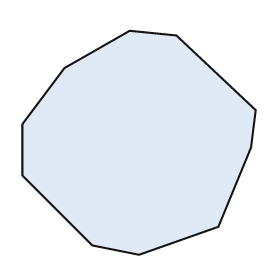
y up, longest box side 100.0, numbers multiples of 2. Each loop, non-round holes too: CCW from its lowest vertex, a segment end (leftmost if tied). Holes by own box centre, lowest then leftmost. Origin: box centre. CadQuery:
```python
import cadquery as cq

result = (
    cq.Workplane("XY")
    .moveTo(0.0, -48.0)
    .lineTo(34.0, -36.0)
    .lineTo(48.0, -2.0)
    .lineTo(50.0, 14.0)
    .lineTo(16.0, 46.0)
    .lineTo(-4.0, 48.0)
    .lineTo(-32.0, 32.0)
    .lineTo(-50.0, 8.0)
    .lineTo(-50.0, -14.0)
    .lineTo(-20.0, -44.0)
    .close()
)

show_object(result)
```